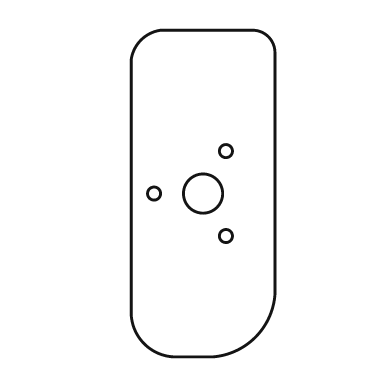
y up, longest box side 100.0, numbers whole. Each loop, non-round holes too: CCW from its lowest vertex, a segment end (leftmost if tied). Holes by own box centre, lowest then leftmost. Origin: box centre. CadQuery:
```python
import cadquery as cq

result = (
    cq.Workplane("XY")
    .moveTo(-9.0, -50.0)
    .lineTo(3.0, -50.0)
    .threePointArc((16.0, -44.0), (22.0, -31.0))
    .lineTo(22.0, 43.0)
    .threePointArc((20.0, 48.0), (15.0, 50.0))
    .lineTo(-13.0, 50.0)
    .threePointArc((-19.0, 47.0), (-22.0, 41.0))
    .lineTo(-22.0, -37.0)
    .threePointArc((-18.0, -46.0), (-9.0, -50.0))
    .close()
    .moveTo(7.0, -13.0)
    .circle(2.0)
    .moveTo(-15.0, 0.0)
    .circle(2.0)
    .moveTo(0.0, 0.0)
    .circle(6.0)
    .moveTo(7.0, 13.0)
    .circle(2.0)
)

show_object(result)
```